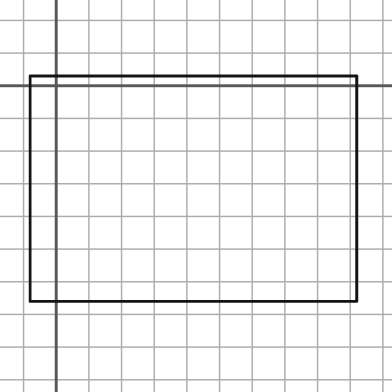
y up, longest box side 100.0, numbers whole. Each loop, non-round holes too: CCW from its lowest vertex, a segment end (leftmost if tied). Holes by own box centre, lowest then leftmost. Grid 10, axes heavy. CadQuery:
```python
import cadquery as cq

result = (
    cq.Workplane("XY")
    .moveTo(-8.0, -66.0)
    .lineTo(92.0, -66.0)
    .lineTo(92.0, 3.0)
    .lineTo(-8.0, 3.0)
    .close()
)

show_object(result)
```